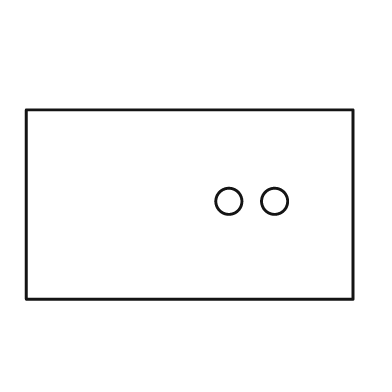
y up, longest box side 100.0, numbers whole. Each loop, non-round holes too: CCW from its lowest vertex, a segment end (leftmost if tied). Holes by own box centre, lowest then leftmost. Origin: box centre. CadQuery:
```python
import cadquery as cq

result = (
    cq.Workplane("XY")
    .moveTo(-50.0, -29.0)
    .lineTo(50.0, -29.0)
    .lineTo(50.0, 29.0)
    .lineTo(-50.0, 29.0)
    .close()
    .moveTo(12.0, 1.0)
    .circle(4.0)
    .moveTo(26.0, 1.0)
    .circle(4.0)
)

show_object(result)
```